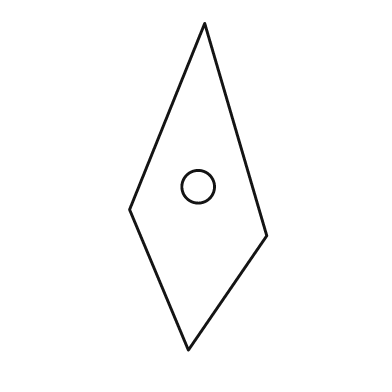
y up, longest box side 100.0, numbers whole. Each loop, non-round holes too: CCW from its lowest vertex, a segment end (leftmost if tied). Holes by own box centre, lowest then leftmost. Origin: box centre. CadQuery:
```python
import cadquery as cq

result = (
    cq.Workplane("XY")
    .moveTo(-3.0, -50.0)
    .lineTo(21.0, -15.0)
    .lineTo(2.0, 50.0)
    .lineTo(-21.0, -7.0)
    .close()
    .moveTo(0.0, 0.0)
    .circle(5.0)
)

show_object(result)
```